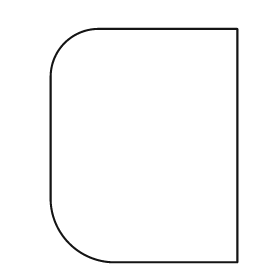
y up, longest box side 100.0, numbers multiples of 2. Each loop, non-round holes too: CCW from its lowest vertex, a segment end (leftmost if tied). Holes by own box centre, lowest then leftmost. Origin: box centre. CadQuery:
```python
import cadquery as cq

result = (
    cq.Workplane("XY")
    .moveTo(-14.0, -50.0)
    .lineTo(40.0, -50.0)
    .lineTo(40.0, 50.0)
    .lineTo(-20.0, 50.0)
    .threePointArc((-34.0, 44.0), (-40.0, 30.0))
    .lineTo(-40.0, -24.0)
    .threePointArc((-32.0, -42.0), (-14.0, -50.0))
    .close()
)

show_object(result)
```